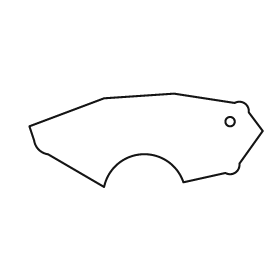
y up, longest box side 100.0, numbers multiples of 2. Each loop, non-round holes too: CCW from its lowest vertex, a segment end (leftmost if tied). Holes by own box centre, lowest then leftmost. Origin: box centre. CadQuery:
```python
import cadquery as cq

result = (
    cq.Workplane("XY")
    .moveTo(-18.0, -20.0)
    .threePointArc((-2.0, -6.0), (16.0, -18.0))
    .lineTo(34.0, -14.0)
    .threePointArc((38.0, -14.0), (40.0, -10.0))
    .lineTo(50.0, 4.0)
    .lineTo(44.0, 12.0)
    .threePointArc((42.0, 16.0), (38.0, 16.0))
    .lineTo(12.0, 20.0)
    .lineTo(-18.0, 18.0)
    .lineTo(-50.0, 6.0)
    .lineTo(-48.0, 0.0)
    .threePointArc((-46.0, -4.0), (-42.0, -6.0))
    .close()
    .moveTo(36.0, 8.0)
    .circle(2.0)
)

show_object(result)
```